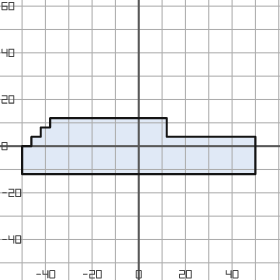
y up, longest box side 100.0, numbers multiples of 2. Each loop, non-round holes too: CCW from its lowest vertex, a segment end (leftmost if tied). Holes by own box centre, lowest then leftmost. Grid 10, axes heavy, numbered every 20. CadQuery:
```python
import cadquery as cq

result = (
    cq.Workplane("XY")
    .moveTo(-50.0, -12.0)
    .lineTo(50.0, -12.0)
    .lineTo(50.0, 4.0)
    .lineTo(12.0, 4.0)
    .lineTo(12.0, 12.0)
    .lineTo(-38.0, 12.0)
    .lineTo(-38.0, 8.0)
    .lineTo(-42.0, 8.0)
    .lineTo(-42.0, 4.0)
    .lineTo(-46.0, 4.0)
    .lineTo(-46.0, 0.0)
    .lineTo(-50.0, 0.0)
    .close()
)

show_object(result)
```